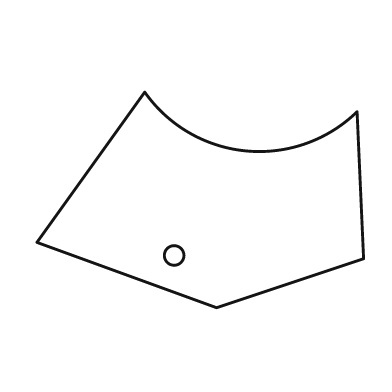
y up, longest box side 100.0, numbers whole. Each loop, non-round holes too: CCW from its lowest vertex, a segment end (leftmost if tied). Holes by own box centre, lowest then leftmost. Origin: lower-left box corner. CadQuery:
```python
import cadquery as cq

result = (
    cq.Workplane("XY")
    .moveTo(55.0, 0.0)
    .lineTo(100.0, 15.0)
    .lineTo(98.0, 60.0)
    .threePointArc((64.0, 48.0), (33.0, 66.0))
    .lineTo(0.0, 20.0)
    .close()
    .moveTo(42.0, 16.0)
    .circle(3.0)
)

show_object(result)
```